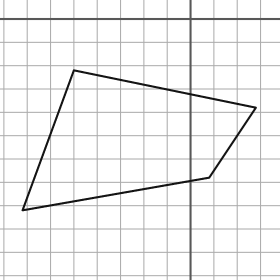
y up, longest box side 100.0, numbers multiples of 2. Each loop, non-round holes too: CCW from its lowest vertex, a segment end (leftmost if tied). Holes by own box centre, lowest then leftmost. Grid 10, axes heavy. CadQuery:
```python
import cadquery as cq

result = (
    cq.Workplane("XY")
    .moveTo(-72.0, -82.0)
    .lineTo(8.0, -68.0)
    .lineTo(28.0, -38.0)
    .lineTo(-50.0, -22.0)
    .close()
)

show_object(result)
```